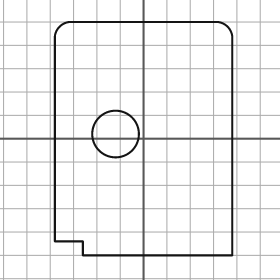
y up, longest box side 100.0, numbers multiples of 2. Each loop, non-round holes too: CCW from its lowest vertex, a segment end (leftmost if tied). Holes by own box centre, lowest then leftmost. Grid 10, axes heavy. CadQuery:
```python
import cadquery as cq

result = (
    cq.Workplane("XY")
    .moveTo(-26.0, -50.0)
    .lineTo(38.0, -50.0)
    .lineTo(38.0, 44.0)
    .threePointArc((36.0, 48.0), (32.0, 50.0))
    .lineTo(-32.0, 50.0)
    .threePointArc((-36.0, 48.0), (-38.0, 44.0))
    .lineTo(-38.0, -44.0)
    .lineTo(-26.0, -44.0)
    .close()
    .moveTo(-12.0, 2.0)
    .circle(10.0)
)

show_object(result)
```